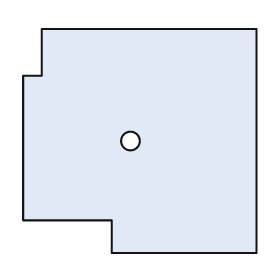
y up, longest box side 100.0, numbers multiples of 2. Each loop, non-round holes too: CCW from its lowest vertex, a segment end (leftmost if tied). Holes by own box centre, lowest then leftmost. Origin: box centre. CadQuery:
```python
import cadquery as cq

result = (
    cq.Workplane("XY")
    .moveTo(-12.0, -48.0)
    .lineTo(50.0, -48.0)
    .lineTo(50.0, 48.0)
    .lineTo(-42.0, 48.0)
    .lineTo(-42.0, 28.0)
    .lineTo(-50.0, 28.0)
    .lineTo(-50.0, -34.0)
    .lineTo(-12.0, -34.0)
    .close()
    .moveTo(-4.0, 0.0)
    .circle(4.0)
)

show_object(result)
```